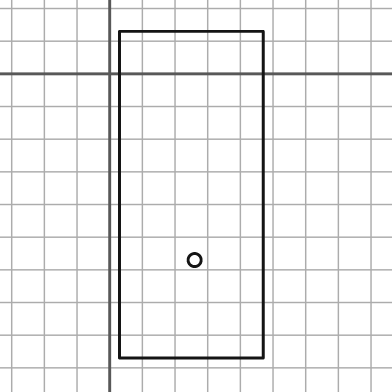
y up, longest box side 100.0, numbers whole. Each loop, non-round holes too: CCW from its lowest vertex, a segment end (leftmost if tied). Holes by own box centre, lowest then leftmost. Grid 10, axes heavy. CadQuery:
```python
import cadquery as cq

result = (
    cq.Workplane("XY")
    .moveTo(3.0, -87.0)
    .lineTo(47.0, -87.0)
    .lineTo(47.0, 13.0)
    .lineTo(3.0, 13.0)
    .close()
    .moveTo(26.0, -57.0)
    .circle(2.0)
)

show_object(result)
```